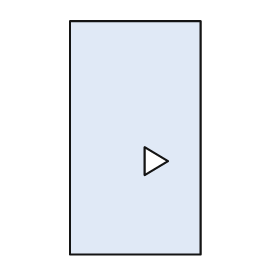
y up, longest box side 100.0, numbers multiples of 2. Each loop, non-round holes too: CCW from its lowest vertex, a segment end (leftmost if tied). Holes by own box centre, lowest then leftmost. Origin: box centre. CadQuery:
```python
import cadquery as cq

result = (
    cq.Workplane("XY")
    .moveTo(-28.0, -50.0)
    .lineTo(28.0, -50.0)
    .lineTo(28.0, 50.0)
    .lineTo(-28.0, 50.0)
    .close()
    .moveTo(4.0, -16.0)
    .lineTo(14.0, -10.0)
    .lineTo(4.0, -4.0)
    .close()
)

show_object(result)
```